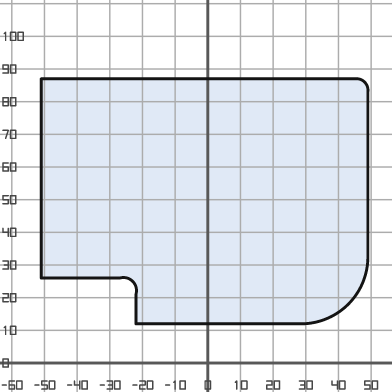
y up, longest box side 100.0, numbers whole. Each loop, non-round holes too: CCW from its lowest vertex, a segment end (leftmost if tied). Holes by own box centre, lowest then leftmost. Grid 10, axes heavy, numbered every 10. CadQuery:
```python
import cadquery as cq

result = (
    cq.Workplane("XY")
    .moveTo(-22.0, 12.0)
    .lineTo(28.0, 12.0)
    .threePointArc((43.0, 18.0), (49.0, 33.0))
    .lineTo(49.0, 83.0)
    .threePointArc((48.0, 86.0), (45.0, 87.0))
    .lineTo(-51.0, 87.0)
    .lineTo(-51.0, 26.0)
    .lineTo(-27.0, 26.0)
    .threePointArc((-23.0, 25.0), (-22.0, 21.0))
    .close()
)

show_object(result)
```